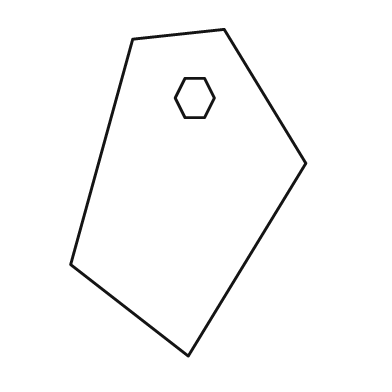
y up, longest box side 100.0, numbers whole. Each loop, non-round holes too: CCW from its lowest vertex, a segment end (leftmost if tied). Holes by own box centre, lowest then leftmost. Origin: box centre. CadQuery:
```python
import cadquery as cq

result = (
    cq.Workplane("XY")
    .moveTo(0.0, -50.0)
    .lineTo(36.0, 9.0)
    .lineTo(11.0, 50.0)
    .lineTo(-17.0, 47.0)
    .lineTo(-36.0, -22.0)
    .close()
    .moveTo(-1.0, 23.0)
    .lineTo(5.0, 23.0)
    .lineTo(8.0, 29.0)
    .lineTo(5.0, 35.0)
    .lineTo(-1.0, 35.0)
    .lineTo(-4.0, 29.0)
    .close()
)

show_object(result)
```